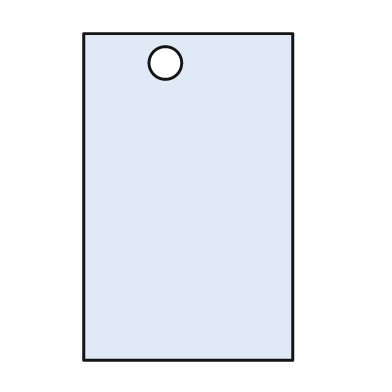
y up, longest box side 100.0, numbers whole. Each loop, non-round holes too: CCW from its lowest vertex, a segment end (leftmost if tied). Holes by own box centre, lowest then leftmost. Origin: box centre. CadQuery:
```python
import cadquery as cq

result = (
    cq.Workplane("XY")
    .moveTo(-32.0, -50.0)
    .lineTo(32.0, -50.0)
    .lineTo(32.0, 50.0)
    .lineTo(-32.0, 50.0)
    .close()
    .moveTo(-7.0, 41.0)
    .circle(5.0)
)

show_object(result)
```